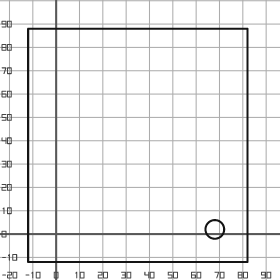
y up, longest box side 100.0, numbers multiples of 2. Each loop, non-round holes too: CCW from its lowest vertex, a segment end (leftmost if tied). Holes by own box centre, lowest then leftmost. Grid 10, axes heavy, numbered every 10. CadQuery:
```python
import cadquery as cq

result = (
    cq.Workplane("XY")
    .moveTo(-12.0, -12.0)
    .lineTo(82.0, -12.0)
    .lineTo(82.0, 88.0)
    .lineTo(-12.0, 88.0)
    .close()
    .moveTo(68.0, 2.0)
    .circle(4.0)
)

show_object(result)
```